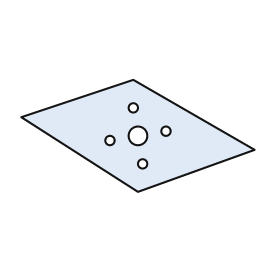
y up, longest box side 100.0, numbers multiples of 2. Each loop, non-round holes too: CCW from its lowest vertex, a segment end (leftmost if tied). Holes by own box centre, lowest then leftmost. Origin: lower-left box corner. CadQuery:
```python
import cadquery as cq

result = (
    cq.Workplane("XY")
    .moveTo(50.0, 0.0)
    .lineTo(100.0, 18.0)
    .lineTo(48.0, 48.0)
    .lineTo(0.0, 32.0)
    .close()
    .moveTo(52.0, 12.0)
    .circle(2.0)
    .moveTo(38.0, 22.0)
    .circle(2.0)
    .moveTo(50.0, 24.0)
    .circle(4.0)
    .moveTo(62.0, 26.0)
    .circle(2.0)
    .moveTo(48.0, 36.0)
    .circle(2.0)
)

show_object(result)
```